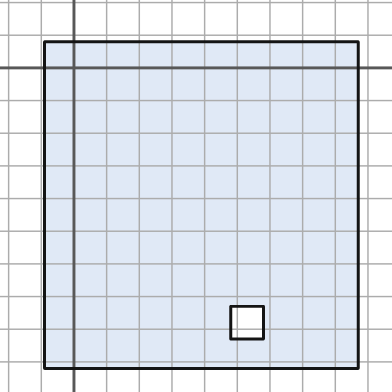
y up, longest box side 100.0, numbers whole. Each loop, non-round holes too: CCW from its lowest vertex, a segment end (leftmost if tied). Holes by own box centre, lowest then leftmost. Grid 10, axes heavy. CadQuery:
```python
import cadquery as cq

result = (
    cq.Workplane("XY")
    .moveTo(-9.0, -92.0)
    .lineTo(87.0, -92.0)
    .lineTo(87.0, 8.0)
    .lineTo(-9.0, 8.0)
    .close()
    .moveTo(48.0, -83.0)
    .lineTo(58.0, -83.0)
    .lineTo(58.0, -73.0)
    .lineTo(48.0, -73.0)
    .close()
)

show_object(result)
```